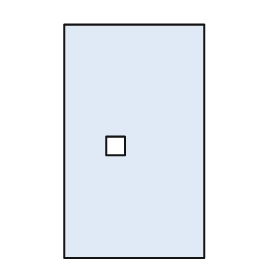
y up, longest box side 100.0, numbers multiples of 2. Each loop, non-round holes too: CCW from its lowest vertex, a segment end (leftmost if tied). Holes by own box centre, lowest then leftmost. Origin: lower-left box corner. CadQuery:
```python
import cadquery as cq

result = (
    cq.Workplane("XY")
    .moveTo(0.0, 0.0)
    .lineTo(60.0, 0.0)
    .lineTo(60.0, 100.0)
    .lineTo(0.0, 100.0)
    .close()
    .moveTo(18.0, 44.0)
    .lineTo(26.0, 44.0)
    .lineTo(26.0, 52.0)
    .lineTo(18.0, 52.0)
    .close()
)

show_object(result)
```